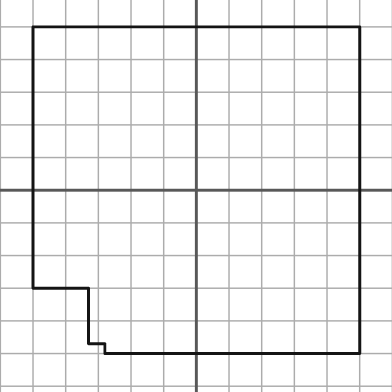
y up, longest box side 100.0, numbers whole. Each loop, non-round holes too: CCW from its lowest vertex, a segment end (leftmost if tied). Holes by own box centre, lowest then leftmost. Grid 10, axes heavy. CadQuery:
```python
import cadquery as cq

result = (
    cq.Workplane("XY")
    .moveTo(-28.0, -50.0)
    .lineTo(50.0, -50.0)
    .lineTo(50.0, 50.0)
    .lineTo(-50.0, 50.0)
    .lineTo(-50.0, -30.0)
    .lineTo(-33.0, -30.0)
    .lineTo(-33.0, -47.0)
    .lineTo(-28.0, -47.0)
    .close()
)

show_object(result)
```